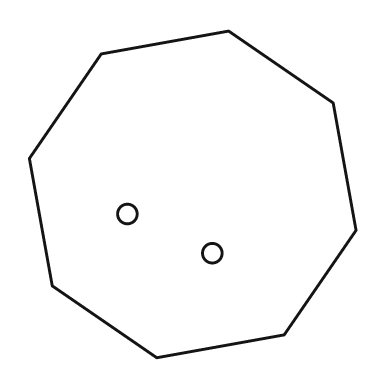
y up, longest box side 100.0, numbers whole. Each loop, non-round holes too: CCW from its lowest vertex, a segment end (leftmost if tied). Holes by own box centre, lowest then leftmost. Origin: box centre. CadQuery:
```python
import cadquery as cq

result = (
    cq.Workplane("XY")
    .moveTo(-11.0, -50.0)
    .lineTo(28.0, -43.0)
    .lineTo(50.0, -11.0)
    .lineTo(43.0, 28.0)
    .lineTo(11.0, 50.0)
    .lineTo(-28.0, 43.0)
    .lineTo(-50.0, 11.0)
    .lineTo(-43.0, -28.0)
    .close()
    .moveTo(6.0, -18.0)
    .circle(3.0)
    .moveTo(-20.0, -6.0)
    .circle(3.0)
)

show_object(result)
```